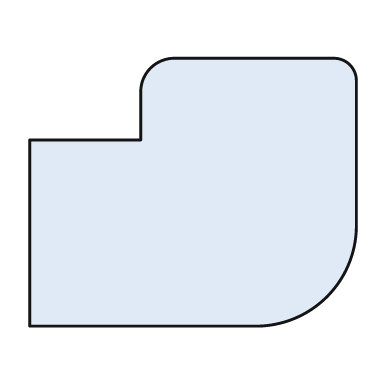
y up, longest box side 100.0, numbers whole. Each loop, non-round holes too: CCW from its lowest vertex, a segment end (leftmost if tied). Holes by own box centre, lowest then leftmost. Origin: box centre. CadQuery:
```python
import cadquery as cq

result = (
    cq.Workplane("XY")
    .moveTo(-50.0, -41.0)
    .lineTo(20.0, -41.0)
    .threePointArc((41.0, -32.0), (50.0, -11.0))
    .lineTo(50.0, 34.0)
    .threePointArc((48.0, 39.0), (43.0, 41.0))
    .lineTo(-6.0, 41.0)
    .threePointArc((-13.0, 38.0), (-16.0, 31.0))
    .lineTo(-16.0, 16.0)
    .lineTo(-50.0, 16.0)
    .close()
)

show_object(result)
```